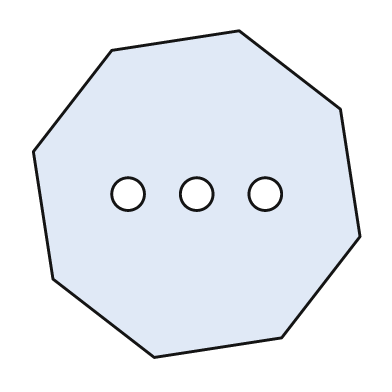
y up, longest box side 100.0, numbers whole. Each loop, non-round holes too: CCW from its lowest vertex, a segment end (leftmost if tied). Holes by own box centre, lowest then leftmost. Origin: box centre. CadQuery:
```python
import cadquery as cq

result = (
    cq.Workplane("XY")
    .moveTo(-13.0, -50.0)
    .lineTo(26.0, -44.0)
    .lineTo(50.0, -13.0)
    .lineTo(44.0, 26.0)
    .lineTo(13.0, 50.0)
    .lineTo(-26.0, 44.0)
    .lineTo(-50.0, 13.0)
    .lineTo(-44.0, -26.0)
    .close()
    .moveTo(-21.0, 0.0)
    .circle(5.0)
    .moveTo(0.0, 0.0)
    .circle(5.0)
    .moveTo(21.0, 0.0)
    .circle(5.0)
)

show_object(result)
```